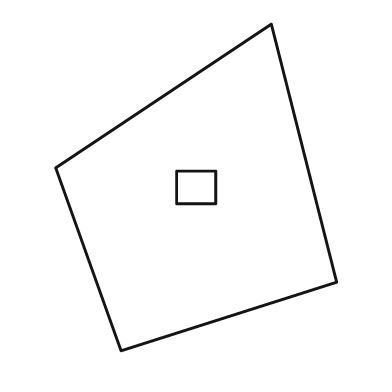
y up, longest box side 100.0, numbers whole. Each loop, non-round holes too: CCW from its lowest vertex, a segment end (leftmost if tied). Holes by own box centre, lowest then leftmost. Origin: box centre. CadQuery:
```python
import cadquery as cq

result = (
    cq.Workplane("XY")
    .moveTo(-23.0, -50.0)
    .lineTo(43.0, -29.0)
    .lineTo(23.0, 50.0)
    .lineTo(-43.0, 6.0)
    .close()
    .moveTo(-6.0, -5.0)
    .lineTo(6.0, -5.0)
    .lineTo(6.0, 5.0)
    .lineTo(-6.0, 5.0)
    .close()
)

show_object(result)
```